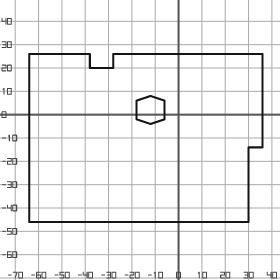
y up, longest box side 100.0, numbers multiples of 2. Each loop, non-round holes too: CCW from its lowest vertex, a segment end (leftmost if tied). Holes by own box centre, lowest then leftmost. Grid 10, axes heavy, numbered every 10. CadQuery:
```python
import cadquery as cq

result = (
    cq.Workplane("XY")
    .moveTo(-64.0, -46.0)
    .lineTo(30.0, -46.0)
    .lineTo(30.0, -14.0)
    .lineTo(36.0, -14.0)
    .lineTo(36.0, 26.0)
    .lineTo(-28.0, 26.0)
    .lineTo(-28.0, 20.0)
    .lineTo(-38.0, 20.0)
    .lineTo(-38.0, 26.0)
    .lineTo(-64.0, 26.0)
    .close()
    .moveTo(-12.0, -4.0)
    .lineTo(-6.0, -2.0)
    .lineTo(-6.0, 6.0)
    .lineTo(-12.0, 8.0)
    .lineTo(-18.0, 6.0)
    .lineTo(-18.0, -2.0)
    .close()
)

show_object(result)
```